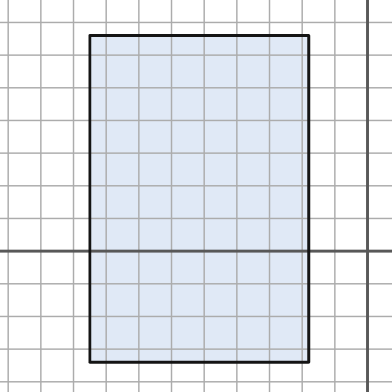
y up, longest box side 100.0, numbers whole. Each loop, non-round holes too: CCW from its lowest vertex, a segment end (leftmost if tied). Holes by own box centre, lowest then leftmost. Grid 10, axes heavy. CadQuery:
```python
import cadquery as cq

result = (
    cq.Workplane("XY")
    .moveTo(-85.0, -34.0)
    .lineTo(-18.0, -34.0)
    .lineTo(-18.0, 66.0)
    .lineTo(-85.0, 66.0)
    .close()
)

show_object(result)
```